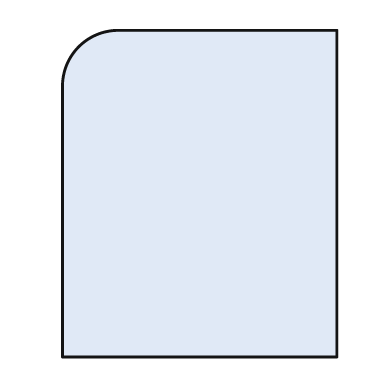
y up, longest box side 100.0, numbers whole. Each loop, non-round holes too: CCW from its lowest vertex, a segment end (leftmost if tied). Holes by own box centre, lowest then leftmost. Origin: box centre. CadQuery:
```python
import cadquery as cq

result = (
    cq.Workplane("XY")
    .moveTo(-42.0, -50.0)
    .lineTo(42.0, -50.0)
    .lineTo(42.0, 50.0)
    .lineTo(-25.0, 50.0)
    .threePointArc((-37.0, 45.0), (-42.0, 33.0))
    .close()
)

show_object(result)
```